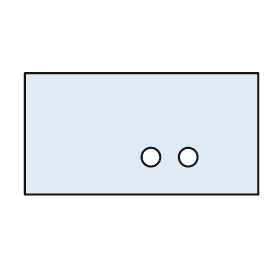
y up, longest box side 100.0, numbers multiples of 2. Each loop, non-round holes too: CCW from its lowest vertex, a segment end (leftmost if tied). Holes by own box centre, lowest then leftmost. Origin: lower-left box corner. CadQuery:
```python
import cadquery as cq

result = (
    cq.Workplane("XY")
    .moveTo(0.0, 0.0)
    .lineTo(100.0, 0.0)
    .lineTo(100.0, 52.0)
    .lineTo(0.0, 52.0)
    .close()
    .moveTo(54.0, 16.0)
    .circle(4.0)
    .moveTo(70.0, 16.0)
    .circle(4.0)
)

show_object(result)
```